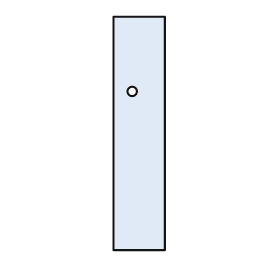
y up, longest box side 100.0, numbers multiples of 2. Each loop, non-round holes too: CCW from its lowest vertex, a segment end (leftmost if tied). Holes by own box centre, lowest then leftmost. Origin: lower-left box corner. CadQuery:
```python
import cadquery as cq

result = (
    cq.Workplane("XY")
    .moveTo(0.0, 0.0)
    .lineTo(22.0, 0.0)
    .lineTo(22.0, 100.0)
    .lineTo(0.0, 100.0)
    .close()
    .moveTo(8.0, 68.0)
    .circle(2.0)
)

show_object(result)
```